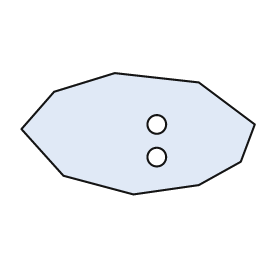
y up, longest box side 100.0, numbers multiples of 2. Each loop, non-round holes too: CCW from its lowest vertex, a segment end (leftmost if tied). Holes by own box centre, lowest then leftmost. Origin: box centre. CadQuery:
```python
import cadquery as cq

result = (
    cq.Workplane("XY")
    .moveTo(-2.0, -26.0)
    .lineTo(26.0, -22.0)
    .lineTo(44.0, -12.0)
    .lineTo(50.0, 4.0)
    .lineTo(26.0, 22.0)
    .lineTo(-10.0, 26.0)
    .lineTo(-36.0, 18.0)
    .lineTo(-50.0, 2.0)
    .lineTo(-32.0, -18.0)
    .close()
    .moveTo(8.0, -10.0)
    .circle(4.0)
    .moveTo(8.0, 4.0)
    .circle(4.0)
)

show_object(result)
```